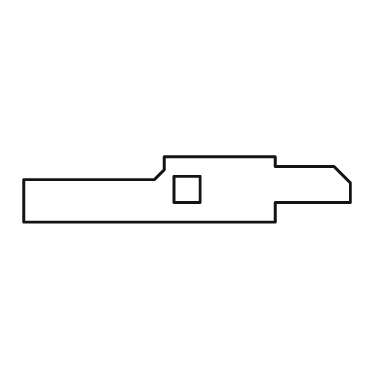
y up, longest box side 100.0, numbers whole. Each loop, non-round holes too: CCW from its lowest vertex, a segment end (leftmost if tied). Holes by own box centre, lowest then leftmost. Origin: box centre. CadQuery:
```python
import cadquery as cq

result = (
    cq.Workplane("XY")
    .moveTo(-50.0, -10.0)
    .lineTo(27.0, -10.0)
    .lineTo(27.0, -4.0)
    .lineTo(50.0, -4.0)
    .lineTo(50.0, 2.0)
    .lineTo(45.0, 7.0)
    .lineTo(27.0, 7.0)
    .lineTo(27.0, 10.0)
    .lineTo(-7.0, 10.0)
    .lineTo(-7.0, 6.0)
    .lineTo(-10.0, 3.0)
    .lineTo(-50.0, 3.0)
    .close()
    .moveTo(-4.0, -4.0)
    .lineTo(4.0, -4.0)
    .lineTo(4.0, 4.0)
    .lineTo(-4.0, 4.0)
    .close()
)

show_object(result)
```